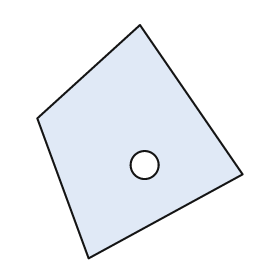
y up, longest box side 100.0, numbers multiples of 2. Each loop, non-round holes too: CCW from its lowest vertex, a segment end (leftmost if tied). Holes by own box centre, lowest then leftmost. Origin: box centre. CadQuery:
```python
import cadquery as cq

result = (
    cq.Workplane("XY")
    .moveTo(-22.0, -50.0)
    .lineTo(44.0, -14.0)
    .lineTo(0.0, 50.0)
    .lineTo(-44.0, 10.0)
    .close()
    .moveTo(2.0, -10.0)
    .circle(6.0)
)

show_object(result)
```